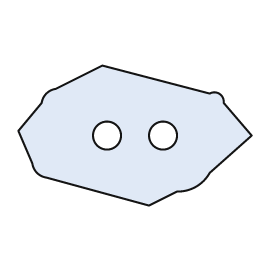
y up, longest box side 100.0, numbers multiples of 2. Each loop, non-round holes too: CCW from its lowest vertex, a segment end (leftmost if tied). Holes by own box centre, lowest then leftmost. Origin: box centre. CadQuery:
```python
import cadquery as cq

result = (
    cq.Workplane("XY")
    .moveTo(6.0, -30.0)
    .lineTo(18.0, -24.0)
    .threePointArc((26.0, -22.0), (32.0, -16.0))
    .lineTo(50.0, 0.0)
    .lineTo(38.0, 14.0)
    .threePointArc((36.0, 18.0), (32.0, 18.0))
    .lineTo(-14.0, 30.0)
    .lineTo(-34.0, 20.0)
    .threePointArc((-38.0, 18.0), (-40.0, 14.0))
    .lineTo(-50.0, 2.0)
    .lineTo(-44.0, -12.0)
    .threePointArc((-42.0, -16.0), (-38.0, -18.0))
    .close()
    .moveTo(-12.0, 0.0)
    .circle(6.0)
    .moveTo(12.0, 0.0)
    .circle(6.0)
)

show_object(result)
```